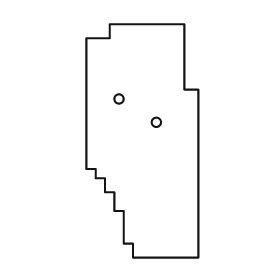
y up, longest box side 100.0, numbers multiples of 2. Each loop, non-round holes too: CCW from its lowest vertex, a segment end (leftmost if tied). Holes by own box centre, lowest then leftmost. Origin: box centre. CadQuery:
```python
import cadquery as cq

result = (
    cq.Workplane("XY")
    .moveTo(-4.0, -50.0)
    .lineTo(24.0, -50.0)
    .lineTo(24.0, 22.0)
    .lineTo(18.0, 22.0)
    .lineTo(18.0, 50.0)
    .lineTo(-14.0, 50.0)
    .lineTo(-14.0, 44.0)
    .lineTo(-24.0, 44.0)
    .lineTo(-24.0, -12.0)
    .lineTo(-20.0, -12.0)
    .lineTo(-20.0, -16.0)
    .lineTo(-16.0, -16.0)
    .lineTo(-16.0, -22.0)
    .lineTo(-12.0, -22.0)
    .lineTo(-12.0, -30.0)
    .lineTo(-8.0, -30.0)
    .lineTo(-8.0, -44.0)
    .lineTo(-4.0, -44.0)
    .close()
    .moveTo(6.0, 8.0)
    .circle(2.0)
    .moveTo(-10.0, 18.0)
    .circle(2.0)
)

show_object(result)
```